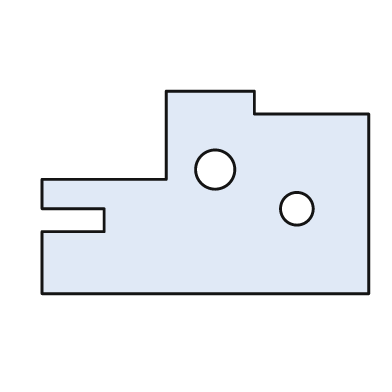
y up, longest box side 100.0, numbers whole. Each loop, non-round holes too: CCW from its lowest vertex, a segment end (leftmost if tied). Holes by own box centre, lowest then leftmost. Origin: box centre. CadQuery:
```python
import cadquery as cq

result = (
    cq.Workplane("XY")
    .moveTo(-50.0, -31.0)
    .lineTo(50.0, -31.0)
    .lineTo(50.0, 24.0)
    .lineTo(15.0, 24.0)
    .lineTo(15.0, 31.0)
    .lineTo(-12.0, 31.0)
    .lineTo(-12.0, 4.0)
    .lineTo(-50.0, 4.0)
    .lineTo(-50.0, -5.0)
    .lineTo(-31.0, -5.0)
    .lineTo(-31.0, -12.0)
    .lineTo(-50.0, -12.0)
    .close()
    .moveTo(28.0, -5.0)
    .circle(5.0)
    .moveTo(3.0, 7.0)
    .circle(6.0)
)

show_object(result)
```